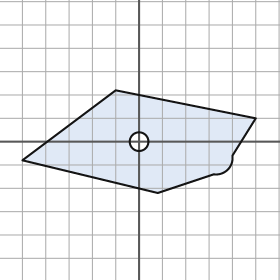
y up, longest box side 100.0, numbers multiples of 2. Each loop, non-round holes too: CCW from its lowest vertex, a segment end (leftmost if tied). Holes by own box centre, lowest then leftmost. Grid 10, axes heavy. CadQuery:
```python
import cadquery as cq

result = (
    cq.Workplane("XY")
    .moveTo(8.0, -22.0)
    .lineTo(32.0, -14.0)
    .threePointArc((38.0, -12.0), (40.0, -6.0))
    .lineTo(50.0, 10.0)
    .lineTo(-10.0, 22.0)
    .lineTo(-50.0, -8.0)
    .close()
    .moveTo(0.0, 0.0)
    .circle(4.0)
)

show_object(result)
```